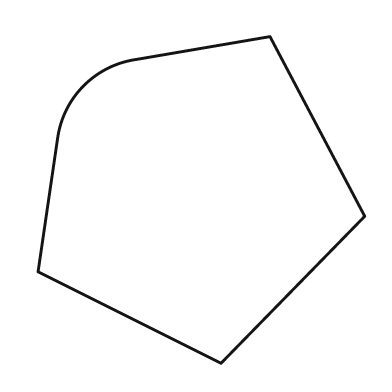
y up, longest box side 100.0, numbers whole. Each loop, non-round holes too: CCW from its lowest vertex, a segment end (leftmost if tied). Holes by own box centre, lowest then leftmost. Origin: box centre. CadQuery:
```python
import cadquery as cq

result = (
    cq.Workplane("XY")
    .moveTo(6.0, -50.0)
    .lineTo(50.0, -5.0)
    .lineTo(21.0, 50.0)
    .lineTo(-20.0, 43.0)
    .threePointArc((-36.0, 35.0), (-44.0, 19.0))
    .lineTo(-50.0, -22.0)
    .close()
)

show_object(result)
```